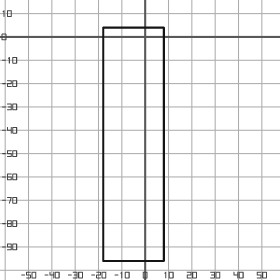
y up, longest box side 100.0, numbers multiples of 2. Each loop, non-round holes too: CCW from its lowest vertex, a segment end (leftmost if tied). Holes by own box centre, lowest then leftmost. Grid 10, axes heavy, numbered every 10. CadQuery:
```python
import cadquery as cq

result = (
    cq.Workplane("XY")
    .moveTo(-18.0, -96.0)
    .lineTo(8.0, -96.0)
    .lineTo(8.0, 4.0)
    .lineTo(-18.0, 4.0)
    .close()
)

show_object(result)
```